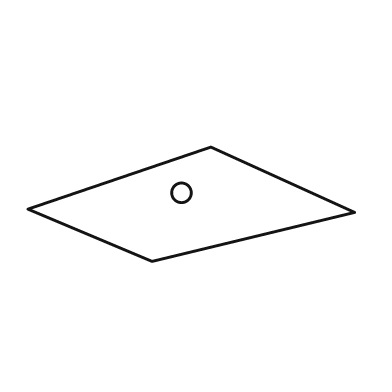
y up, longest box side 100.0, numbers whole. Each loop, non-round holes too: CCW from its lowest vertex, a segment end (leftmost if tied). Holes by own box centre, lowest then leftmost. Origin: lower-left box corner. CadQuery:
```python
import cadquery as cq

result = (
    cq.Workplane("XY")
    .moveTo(38.0, 0.0)
    .lineTo(100.0, 15.0)
    .lineTo(56.0, 35.0)
    .lineTo(0.0, 16.0)
    .close()
    .moveTo(47.0, 21.0)
    .circle(3.0)
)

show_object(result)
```